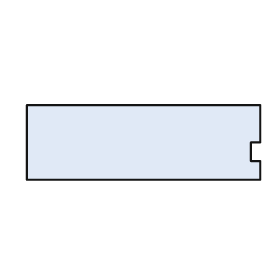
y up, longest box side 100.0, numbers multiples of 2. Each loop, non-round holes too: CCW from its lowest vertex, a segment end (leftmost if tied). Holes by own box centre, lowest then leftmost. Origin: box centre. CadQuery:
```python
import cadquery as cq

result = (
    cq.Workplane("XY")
    .moveTo(-50.0, -16.0)
    .lineTo(50.0, -16.0)
    .lineTo(50.0, -8.0)
    .lineTo(46.0, -8.0)
    .lineTo(46.0, 0.0)
    .lineTo(50.0, 0.0)
    .lineTo(50.0, 16.0)
    .lineTo(-50.0, 16.0)
    .close()
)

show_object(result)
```